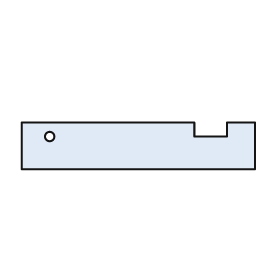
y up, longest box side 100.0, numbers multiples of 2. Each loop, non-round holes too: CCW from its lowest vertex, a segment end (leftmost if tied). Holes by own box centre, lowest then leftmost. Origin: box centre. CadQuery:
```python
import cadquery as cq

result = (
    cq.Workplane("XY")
    .moveTo(-50.0, -10.0)
    .lineTo(50.0, -10.0)
    .lineTo(50.0, 10.0)
    .lineTo(38.0, 10.0)
    .lineTo(38.0, 4.0)
    .lineTo(24.0, 4.0)
    .lineTo(24.0, 10.0)
    .lineTo(-50.0, 10.0)
    .close()
    .moveTo(-38.0, 4.0)
    .circle(2.0)
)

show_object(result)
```